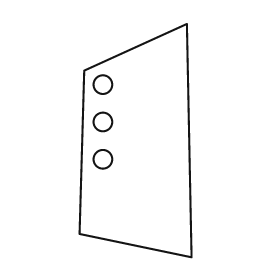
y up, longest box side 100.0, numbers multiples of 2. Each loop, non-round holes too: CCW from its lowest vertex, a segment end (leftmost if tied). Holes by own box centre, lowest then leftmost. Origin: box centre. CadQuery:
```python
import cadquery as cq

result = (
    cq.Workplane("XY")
    .moveTo(24.0, -50.0)
    .lineTo(22.0, 50.0)
    .lineTo(-22.0, 30.0)
    .lineTo(-24.0, -40.0)
    .close()
    .moveTo(-14.0, -8.0)
    .circle(4.0)
    .moveTo(-14.0, 8.0)
    .circle(4.0)
    .moveTo(-14.0, 24.0)
    .circle(4.0)
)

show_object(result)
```